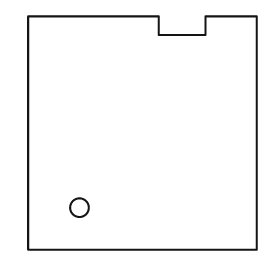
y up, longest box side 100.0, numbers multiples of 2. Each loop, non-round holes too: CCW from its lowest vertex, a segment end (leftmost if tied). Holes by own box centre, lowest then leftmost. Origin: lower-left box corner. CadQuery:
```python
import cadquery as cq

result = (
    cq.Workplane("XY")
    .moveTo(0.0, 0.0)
    .lineTo(98.0, 0.0)
    .lineTo(98.0, 100.0)
    .lineTo(76.0, 100.0)
    .lineTo(76.0, 92.0)
    .lineTo(56.0, 92.0)
    .lineTo(56.0, 100.0)
    .lineTo(0.0, 100.0)
    .close()
    .moveTo(22.0, 18.0)
    .circle(4.0)
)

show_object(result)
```